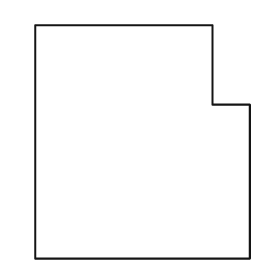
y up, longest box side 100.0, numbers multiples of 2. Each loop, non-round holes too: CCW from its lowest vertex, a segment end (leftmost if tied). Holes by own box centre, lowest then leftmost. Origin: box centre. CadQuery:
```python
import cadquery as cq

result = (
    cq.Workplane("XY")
    .moveTo(-46.0, -50.0)
    .lineTo(46.0, -50.0)
    .lineTo(46.0, 16.0)
    .lineTo(30.0, 16.0)
    .lineTo(30.0, 50.0)
    .lineTo(-46.0, 50.0)
    .close()
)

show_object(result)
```